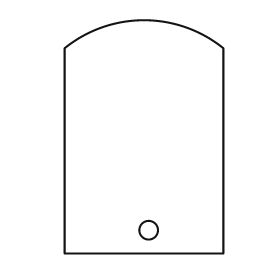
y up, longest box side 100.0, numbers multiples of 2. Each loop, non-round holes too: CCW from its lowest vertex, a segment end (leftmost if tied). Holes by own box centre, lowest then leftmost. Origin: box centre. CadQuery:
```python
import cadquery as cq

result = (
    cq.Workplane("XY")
    .moveTo(-34.0, -50.0)
    .lineTo(34.0, -50.0)
    .lineTo(34.0, 38.0)
    .threePointArc((0.0, 50.0), (-34.0, 38.0))
    .close()
    .moveTo(2.0, -40.0)
    .circle(4.0)
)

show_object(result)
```